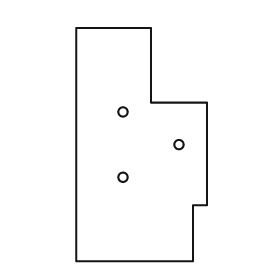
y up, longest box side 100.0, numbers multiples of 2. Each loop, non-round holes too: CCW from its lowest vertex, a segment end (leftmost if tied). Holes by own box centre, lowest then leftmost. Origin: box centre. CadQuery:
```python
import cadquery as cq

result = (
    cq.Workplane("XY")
    .moveTo(-28.0, -50.0)
    .lineTo(22.0, -50.0)
    .lineTo(22.0, -26.0)
    .lineTo(28.0, -26.0)
    .lineTo(28.0, 18.0)
    .lineTo(4.0, 18.0)
    .lineTo(4.0, 50.0)
    .lineTo(-28.0, 50.0)
    .close()
    .moveTo(-8.0, -14.0)
    .circle(2.0)
    .moveTo(16.0, 0.0)
    .circle(2.0)
    .moveTo(-8.0, 14.0)
    .circle(2.0)
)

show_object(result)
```